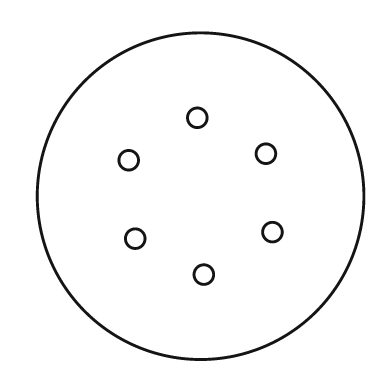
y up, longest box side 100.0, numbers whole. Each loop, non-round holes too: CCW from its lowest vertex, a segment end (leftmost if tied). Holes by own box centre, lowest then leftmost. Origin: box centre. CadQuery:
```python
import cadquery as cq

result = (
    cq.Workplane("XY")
    .moveTo(0.0, 0.0)
    .circle(50.0)
    .moveTo(1.0, -24.0)
    .circle(3.0)
    .moveTo(-20.0, -13.0)
    .circle(3.0)
    .moveTo(22.0, -11.0)
    .circle(3.0)
    .moveTo(-22.0, 11.0)
    .circle(3.0)
    .moveTo(20.0, 13.0)
    .circle(3.0)
    .moveTo(-1.0, 24.0)
    .circle(3.0)
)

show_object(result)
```